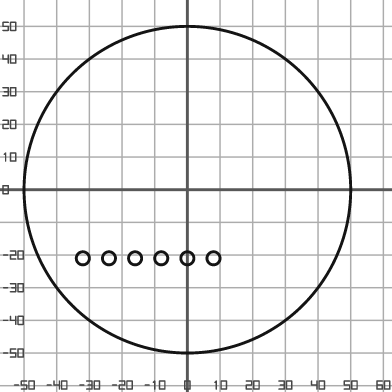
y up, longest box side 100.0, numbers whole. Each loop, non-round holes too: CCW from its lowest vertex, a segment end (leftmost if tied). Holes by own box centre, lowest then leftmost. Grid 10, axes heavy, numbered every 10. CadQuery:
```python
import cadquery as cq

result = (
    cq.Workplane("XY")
    .moveTo(0.0, 0.0)
    .circle(50.0)
    .moveTo(-32.0, -21.0)
    .circle(2.0)
    .moveTo(-24.0, -21.0)
    .circle(2.0)
    .moveTo(-16.0, -21.0)
    .circle(2.0)
    .moveTo(-8.0, -21.0)
    .circle(2.0)
    .moveTo(0.0, -21.0)
    .circle(2.0)
    .moveTo(8.0, -21.0)
    .circle(2.0)
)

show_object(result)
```